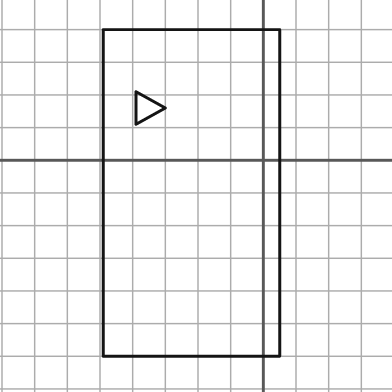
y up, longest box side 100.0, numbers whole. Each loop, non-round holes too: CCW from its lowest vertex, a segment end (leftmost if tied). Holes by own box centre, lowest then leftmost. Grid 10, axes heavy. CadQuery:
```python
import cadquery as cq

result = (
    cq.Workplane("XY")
    .moveTo(-49.0, -60.0)
    .lineTo(5.0, -60.0)
    .lineTo(5.0, 40.0)
    .lineTo(-49.0, 40.0)
    .close()
    .moveTo(-39.0, 11.0)
    .lineTo(-30.0, 16.0)
    .lineTo(-39.0, 21.0)
    .close()
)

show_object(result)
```